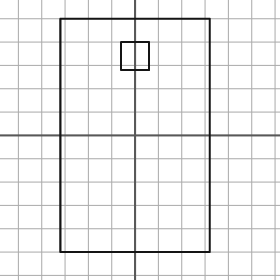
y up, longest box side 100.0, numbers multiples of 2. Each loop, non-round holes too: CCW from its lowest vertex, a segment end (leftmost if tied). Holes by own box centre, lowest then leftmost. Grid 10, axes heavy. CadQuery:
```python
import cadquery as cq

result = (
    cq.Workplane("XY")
    .moveTo(-32.0, -50.0)
    .lineTo(32.0, -50.0)
    .lineTo(32.0, 50.0)
    .lineTo(-32.0, 50.0)
    .close()
    .moveTo(-6.0, 28.0)
    .lineTo(6.0, 28.0)
    .lineTo(6.0, 40.0)
    .lineTo(-6.0, 40.0)
    .close()
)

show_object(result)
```